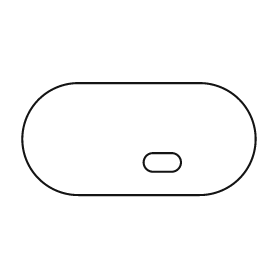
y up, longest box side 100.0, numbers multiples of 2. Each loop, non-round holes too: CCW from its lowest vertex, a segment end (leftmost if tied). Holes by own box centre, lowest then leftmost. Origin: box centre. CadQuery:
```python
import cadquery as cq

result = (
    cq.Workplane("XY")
    .moveTo(-26.0, -24.0)
    .lineTo(26.0, -24.0)
    .threePointArc((50.0, 0.0), (26.0, 24.0))
    .lineTo(-26.0, 24.0)
    .threePointArc((-50.0, 0.0), (-26.0, -24.0))
    .close()
    .moveTo(6.0, -14.0)
    .lineTo(14.0, -14.0)
    .threePointArc((18.0, -10.0), (14.0, -6.0))
    .lineTo(6.0, -6.0)
    .threePointArc((2.0, -10.0), (6.0, -14.0))
    .close()
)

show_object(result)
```